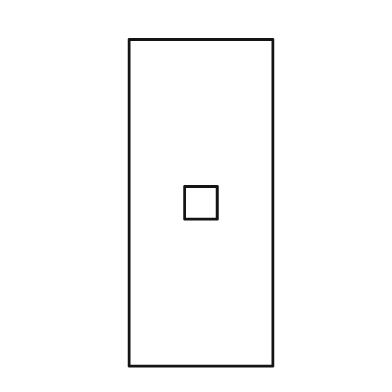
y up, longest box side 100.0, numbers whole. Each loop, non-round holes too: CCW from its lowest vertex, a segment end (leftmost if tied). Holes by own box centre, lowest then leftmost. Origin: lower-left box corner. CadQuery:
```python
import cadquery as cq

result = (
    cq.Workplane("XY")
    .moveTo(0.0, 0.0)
    .lineTo(44.0, 0.0)
    .lineTo(44.0, 100.0)
    .lineTo(0.0, 100.0)
    .close()
    .moveTo(17.0, 45.0)
    .lineTo(27.0, 45.0)
    .lineTo(27.0, 55.0)
    .lineTo(17.0, 55.0)
    .close()
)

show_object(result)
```